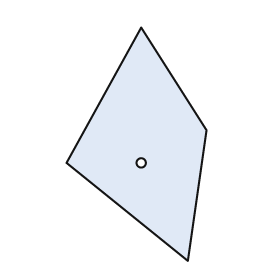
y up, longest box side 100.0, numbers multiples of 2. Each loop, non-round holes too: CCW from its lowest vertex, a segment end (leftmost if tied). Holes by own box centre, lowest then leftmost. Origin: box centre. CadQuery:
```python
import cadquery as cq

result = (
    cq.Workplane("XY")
    .moveTo(22.0, -50.0)
    .lineTo(30.0, 6.0)
    .lineTo(2.0, 50.0)
    .lineTo(-30.0, -8.0)
    .close()
    .moveTo(2.0, -8.0)
    .circle(2.0)
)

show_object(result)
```